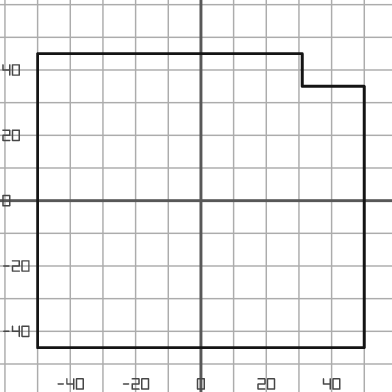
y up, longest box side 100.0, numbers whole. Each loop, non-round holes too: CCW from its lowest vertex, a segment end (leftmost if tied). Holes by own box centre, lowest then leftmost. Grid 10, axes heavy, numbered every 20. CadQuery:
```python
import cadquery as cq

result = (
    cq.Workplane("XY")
    .moveTo(-50.0, -45.0)
    .lineTo(50.0, -45.0)
    .lineTo(50.0, 35.0)
    .lineTo(31.0, 35.0)
    .lineTo(31.0, 45.0)
    .lineTo(-50.0, 45.0)
    .close()
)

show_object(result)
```